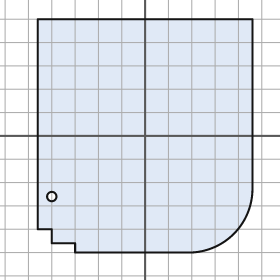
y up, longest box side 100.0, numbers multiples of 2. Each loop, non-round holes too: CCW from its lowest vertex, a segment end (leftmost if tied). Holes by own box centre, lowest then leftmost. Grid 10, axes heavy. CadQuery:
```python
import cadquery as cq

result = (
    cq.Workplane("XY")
    .moveTo(-30.0, -50.0)
    .lineTo(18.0, -50.0)
    .threePointArc((38.0, -42.0), (46.0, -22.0))
    .lineTo(46.0, 50.0)
    .lineTo(-46.0, 50.0)
    .lineTo(-46.0, -40.0)
    .lineTo(-40.0, -40.0)
    .lineTo(-40.0, -46.0)
    .lineTo(-30.0, -46.0)
    .close()
    .moveTo(-40.0, -26.0)
    .circle(2.0)
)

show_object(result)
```